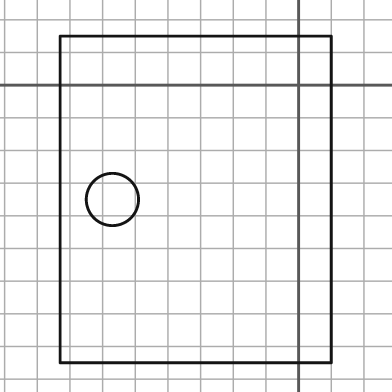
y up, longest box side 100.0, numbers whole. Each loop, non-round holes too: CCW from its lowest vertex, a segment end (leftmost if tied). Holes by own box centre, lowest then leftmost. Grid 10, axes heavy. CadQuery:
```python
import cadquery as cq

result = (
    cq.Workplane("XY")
    .moveTo(-73.0, -85.0)
    .lineTo(10.0, -85.0)
    .lineTo(10.0, 15.0)
    .lineTo(-73.0, 15.0)
    .close()
    .moveTo(-57.0, -35.0)
    .circle(8.0)
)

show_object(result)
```